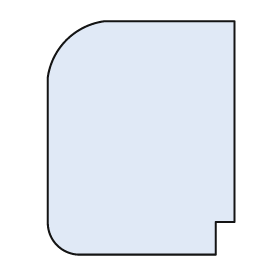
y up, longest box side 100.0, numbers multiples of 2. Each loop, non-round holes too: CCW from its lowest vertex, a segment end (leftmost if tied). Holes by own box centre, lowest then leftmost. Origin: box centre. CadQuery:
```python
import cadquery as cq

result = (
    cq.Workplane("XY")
    .moveTo(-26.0, -50.0)
    .lineTo(32.0, -50.0)
    .lineTo(32.0, -36.0)
    .lineTo(40.0, -36.0)
    .lineTo(40.0, 50.0)
    .lineTo(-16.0, 50.0)
    .threePointArc((-32.0, 42.0), (-40.0, 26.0))
    .lineTo(-40.0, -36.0)
    .threePointArc((-36.0, -46.0), (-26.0, -50.0))
    .close()
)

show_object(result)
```